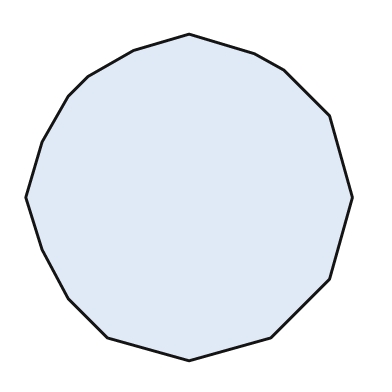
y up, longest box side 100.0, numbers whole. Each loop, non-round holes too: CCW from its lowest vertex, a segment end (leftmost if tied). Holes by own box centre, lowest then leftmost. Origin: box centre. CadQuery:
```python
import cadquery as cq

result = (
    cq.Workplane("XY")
    .moveTo(0.0, -50.0)
    .lineTo(25.0, -43.0)
    .lineTo(43.0, -25.0)
    .lineTo(50.0, 0.0)
    .lineTo(43.0, 25.0)
    .lineTo(29.0, 39.0)
    .lineTo(20.0, 44.0)
    .lineTo(0.0, 50.0)
    .lineTo(-17.0, 45.0)
    .lineTo(-31.0, 37.0)
    .lineTo(-37.0, 31.0)
    .lineTo(-45.0, 17.0)
    .lineTo(-50.0, 0.0)
    .lineTo(-45.0, -16.0)
    .lineTo(-37.0, -31.0)
    .lineTo(-25.0, -43.0)
    .close()
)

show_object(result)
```